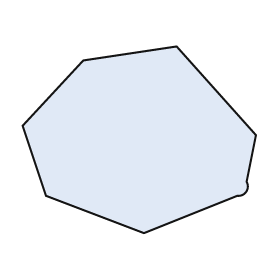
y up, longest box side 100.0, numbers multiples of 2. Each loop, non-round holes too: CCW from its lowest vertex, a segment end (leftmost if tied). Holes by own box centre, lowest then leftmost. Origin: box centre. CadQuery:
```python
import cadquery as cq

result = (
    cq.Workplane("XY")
    .moveTo(2.0, -40.0)
    .lineTo(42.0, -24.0)
    .threePointArc((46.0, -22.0), (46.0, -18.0))
    .lineTo(50.0, 2.0)
    .lineTo(16.0, 40.0)
    .lineTo(-24.0, 34.0)
    .lineTo(-50.0, 6.0)
    .lineTo(-40.0, -24.0)
    .close()
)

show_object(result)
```